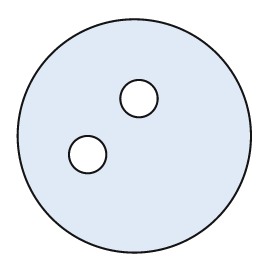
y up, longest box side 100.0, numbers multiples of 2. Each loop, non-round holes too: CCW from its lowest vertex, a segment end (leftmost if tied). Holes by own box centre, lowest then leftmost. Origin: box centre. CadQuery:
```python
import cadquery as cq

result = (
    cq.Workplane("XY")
    .moveTo(0.0, 0.0)
    .circle(50.0)
    .moveTo(-20.0, -8.0)
    .circle(8.0)
    .moveTo(2.0, 16.0)
    .circle(8.0)
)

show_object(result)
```